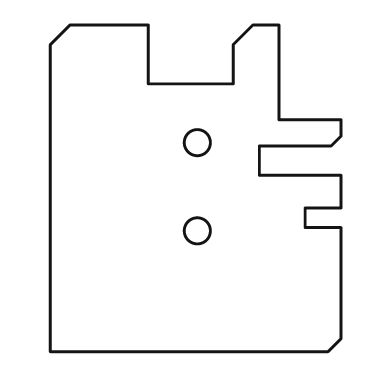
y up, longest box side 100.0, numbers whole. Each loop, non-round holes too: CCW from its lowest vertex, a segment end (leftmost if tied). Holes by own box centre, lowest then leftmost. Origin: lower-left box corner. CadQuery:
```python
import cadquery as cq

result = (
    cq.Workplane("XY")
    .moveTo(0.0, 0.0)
    .lineTo(85.0, 0.0)
    .lineTo(89.0, 4.0)
    .lineTo(89.0, 38.0)
    .lineTo(78.0, 38.0)
    .lineTo(78.0, 44.0)
    .lineTo(89.0, 44.0)
    .lineTo(89.0, 54.0)
    .lineTo(64.0, 54.0)
    .lineTo(64.0, 63.0)
    .lineTo(86.0, 63.0)
    .lineTo(89.0, 66.0)
    .lineTo(89.0, 71.0)
    .lineTo(70.0, 71.0)
    .lineTo(70.0, 100.0)
    .lineTo(62.0, 100.0)
    .lineTo(56.0, 94.0)
    .lineTo(56.0, 82.0)
    .lineTo(30.0, 82.0)
    .lineTo(30.0, 100.0)
    .lineTo(6.0, 100.0)
    .lineTo(0.0, 94.0)
    .close()
    .moveTo(45.0, 37.0)
    .circle(4.0)
    .moveTo(45.0, 64.0)
    .circle(4.0)
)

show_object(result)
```